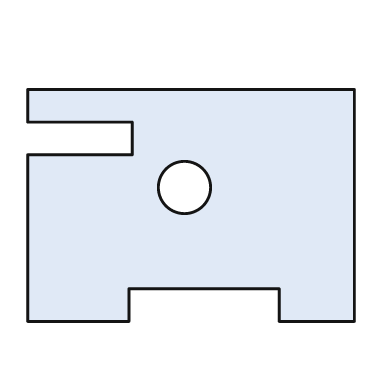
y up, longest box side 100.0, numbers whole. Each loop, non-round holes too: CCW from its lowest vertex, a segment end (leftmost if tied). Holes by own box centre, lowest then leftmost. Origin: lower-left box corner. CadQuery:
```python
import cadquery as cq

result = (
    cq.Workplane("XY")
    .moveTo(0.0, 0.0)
    .lineTo(31.0, 0.0)
    .lineTo(31.0, 10.0)
    .lineTo(77.0, 10.0)
    .lineTo(77.0, 0.0)
    .lineTo(100.0, 0.0)
    .lineTo(100.0, 71.0)
    .lineTo(0.0, 71.0)
    .lineTo(0.0, 61.0)
    .lineTo(32.0, 61.0)
    .lineTo(32.0, 51.0)
    .lineTo(0.0, 51.0)
    .close()
    .moveTo(48.0, 41.0)
    .circle(8.0)
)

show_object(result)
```